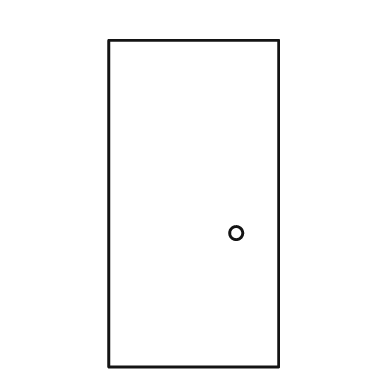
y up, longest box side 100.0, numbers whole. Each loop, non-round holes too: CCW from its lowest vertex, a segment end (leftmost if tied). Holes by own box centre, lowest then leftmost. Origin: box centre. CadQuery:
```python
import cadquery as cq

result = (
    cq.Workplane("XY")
    .moveTo(-26.0, -50.0)
    .lineTo(26.0, -50.0)
    .lineTo(26.0, 50.0)
    .lineTo(-26.0, 50.0)
    .close()
    .moveTo(13.0, -9.0)
    .circle(2.0)
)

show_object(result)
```